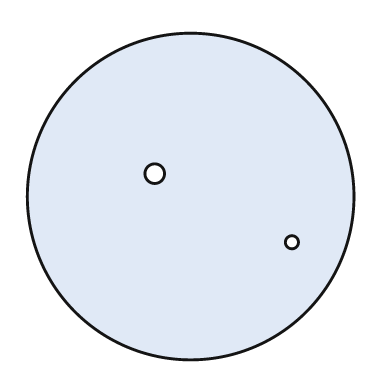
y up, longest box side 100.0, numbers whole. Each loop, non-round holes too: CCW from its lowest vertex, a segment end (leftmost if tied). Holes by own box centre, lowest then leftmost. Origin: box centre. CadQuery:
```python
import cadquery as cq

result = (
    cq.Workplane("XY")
    .moveTo(0.0, 0.0)
    .circle(50.0)
    .moveTo(31.0, -14.0)
    .circle(2.0)
    .moveTo(-11.0, 7.0)
    .circle(3.0)
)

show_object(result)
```